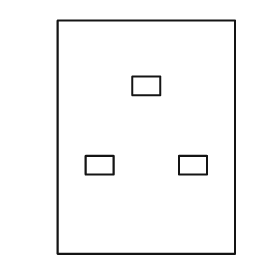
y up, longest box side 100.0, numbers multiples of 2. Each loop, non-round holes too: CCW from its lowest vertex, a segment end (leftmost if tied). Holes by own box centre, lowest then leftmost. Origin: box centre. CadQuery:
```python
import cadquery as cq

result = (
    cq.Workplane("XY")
    .moveTo(-38.0, -50.0)
    .lineTo(38.0, -50.0)
    .lineTo(38.0, 50.0)
    .lineTo(-38.0, 50.0)
    .close()
    .moveTo(-26.0, -16.0)
    .lineTo(-14.0, -16.0)
    .lineTo(-14.0, -8.0)
    .lineTo(-26.0, -8.0)
    .close()
    .moveTo(14.0, -16.0)
    .lineTo(26.0, -16.0)
    .lineTo(26.0, -8.0)
    .lineTo(14.0, -8.0)
    .close()
    .moveTo(-6.0, 18.0)
    .lineTo(6.0, 18.0)
    .lineTo(6.0, 26.0)
    .lineTo(-6.0, 26.0)
    .close()
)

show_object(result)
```